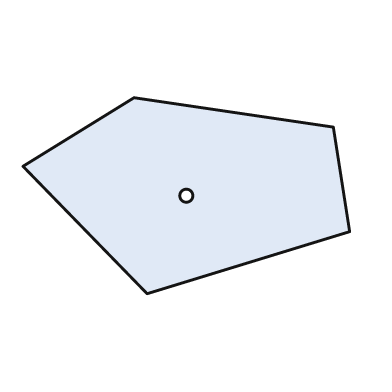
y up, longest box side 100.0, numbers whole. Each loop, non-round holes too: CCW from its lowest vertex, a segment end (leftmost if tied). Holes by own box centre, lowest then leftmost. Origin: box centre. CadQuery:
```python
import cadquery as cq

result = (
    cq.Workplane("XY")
    .moveTo(-12.0, -30.0)
    .lineTo(50.0, -11.0)
    .lineTo(45.0, 21.0)
    .lineTo(-16.0, 30.0)
    .lineTo(-50.0, 9.0)
    .close()
    .moveTo(0.0, 0.0)
    .circle(2.0)
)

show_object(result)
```